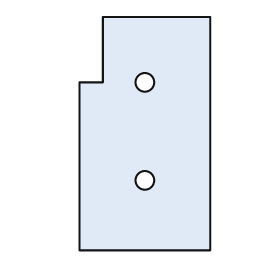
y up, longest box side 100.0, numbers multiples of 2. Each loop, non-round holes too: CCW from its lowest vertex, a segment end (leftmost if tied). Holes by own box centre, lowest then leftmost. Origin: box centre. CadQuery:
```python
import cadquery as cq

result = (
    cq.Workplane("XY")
    .moveTo(-28.0, -50.0)
    .lineTo(28.0, -50.0)
    .lineTo(28.0, 50.0)
    .lineTo(-18.0, 50.0)
    .lineTo(-18.0, 22.0)
    .lineTo(-28.0, 22.0)
    .close()
    .moveTo(0.0, -20.0)
    .circle(4.0)
    .moveTo(0.0, 22.0)
    .circle(4.0)
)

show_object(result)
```